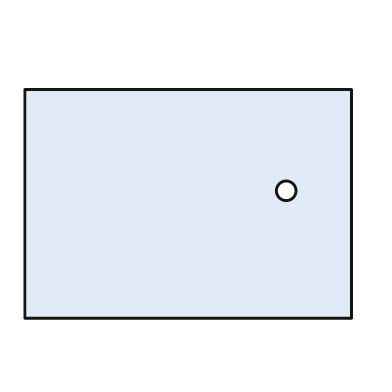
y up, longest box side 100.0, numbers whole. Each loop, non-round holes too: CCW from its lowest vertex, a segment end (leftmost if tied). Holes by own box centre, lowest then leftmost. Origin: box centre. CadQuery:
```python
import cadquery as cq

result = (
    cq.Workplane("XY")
    .moveTo(-50.0, -35.0)
    .lineTo(50.0, -35.0)
    .lineTo(50.0, 35.0)
    .lineTo(-50.0, 35.0)
    .close()
    .moveTo(30.0, 4.0)
    .circle(3.0)
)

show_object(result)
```